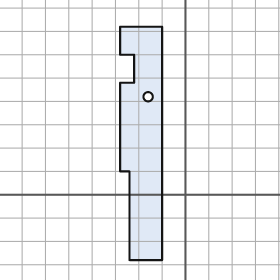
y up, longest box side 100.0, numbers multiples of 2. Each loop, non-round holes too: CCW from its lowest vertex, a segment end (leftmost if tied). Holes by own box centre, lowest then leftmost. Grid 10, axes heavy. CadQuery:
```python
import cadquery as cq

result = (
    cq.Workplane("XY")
    .moveTo(-24.0, -28.0)
    .lineTo(-10.0, -28.0)
    .lineTo(-10.0, 72.0)
    .lineTo(-28.0, 72.0)
    .lineTo(-28.0, 60.0)
    .lineTo(-22.0, 60.0)
    .lineTo(-22.0, 48.0)
    .lineTo(-28.0, 48.0)
    .lineTo(-28.0, 10.0)
    .lineTo(-24.0, 10.0)
    .close()
    .moveTo(-16.0, 42.0)
    .circle(2.0)
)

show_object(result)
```